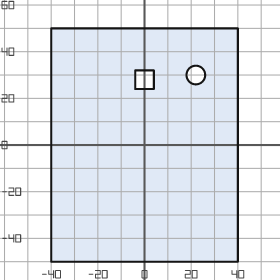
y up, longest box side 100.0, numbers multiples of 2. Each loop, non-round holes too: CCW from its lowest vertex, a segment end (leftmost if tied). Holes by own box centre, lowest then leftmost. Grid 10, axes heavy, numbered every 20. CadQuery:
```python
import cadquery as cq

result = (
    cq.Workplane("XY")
    .moveTo(-40.0, -50.0)
    .lineTo(40.0, -50.0)
    .lineTo(40.0, 50.0)
    .lineTo(-40.0, 50.0)
    .close()
    .moveTo(-4.0, 24.0)
    .lineTo(4.0, 24.0)
    .lineTo(4.0, 32.0)
    .lineTo(-4.0, 32.0)
    .close()
    .moveTo(22.0, 30.0)
    .circle(4.0)
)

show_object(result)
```